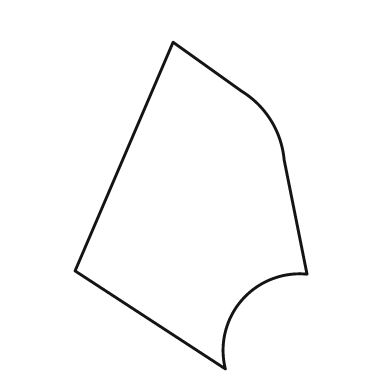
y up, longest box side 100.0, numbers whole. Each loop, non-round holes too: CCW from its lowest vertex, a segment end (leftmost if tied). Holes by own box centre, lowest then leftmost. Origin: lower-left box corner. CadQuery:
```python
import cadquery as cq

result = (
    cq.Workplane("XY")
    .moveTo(46.0, 0.0)
    .threePointArc((51.0, 21.0), (71.0, 29.0))
    .lineTo(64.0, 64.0)
    .threePointArc((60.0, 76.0), (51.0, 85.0))
    .lineTo(30.0, 100.0)
    .lineTo(0.0, 30.0)
    .close()
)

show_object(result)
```